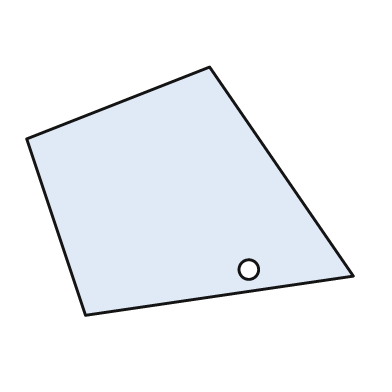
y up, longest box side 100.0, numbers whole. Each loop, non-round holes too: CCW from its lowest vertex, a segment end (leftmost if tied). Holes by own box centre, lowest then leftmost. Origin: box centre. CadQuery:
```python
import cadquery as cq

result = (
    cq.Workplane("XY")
    .moveTo(-32.0, -38.0)
    .lineTo(50.0, -26.0)
    .lineTo(6.0, 38.0)
    .lineTo(-50.0, 16.0)
    .close()
    .moveTo(18.0, -24.0)
    .circle(3.0)
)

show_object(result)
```